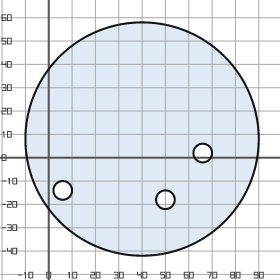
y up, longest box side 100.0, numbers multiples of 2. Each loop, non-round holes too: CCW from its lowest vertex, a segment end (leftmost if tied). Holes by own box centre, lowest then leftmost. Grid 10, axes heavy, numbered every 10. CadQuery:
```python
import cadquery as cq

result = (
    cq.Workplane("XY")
    .moveTo(40.0, 8.0)
    .circle(50.0)
    .moveTo(50.0, -18.0)
    .circle(4.0)
    .moveTo(6.0, -14.0)
    .circle(4.0)
    .moveTo(66.0, 2.0)
    .circle(4.0)
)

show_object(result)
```